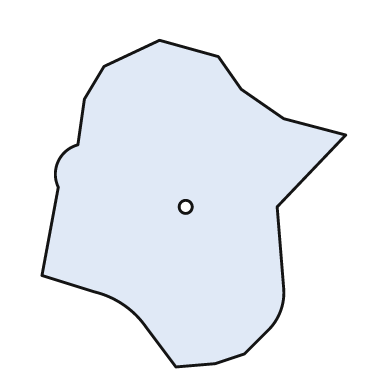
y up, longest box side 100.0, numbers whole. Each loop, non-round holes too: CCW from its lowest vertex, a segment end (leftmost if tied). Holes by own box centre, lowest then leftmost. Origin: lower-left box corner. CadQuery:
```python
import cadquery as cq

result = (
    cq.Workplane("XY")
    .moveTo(41.0, 0.0)
    .lineTo(53.0, 1.0)
    .lineTo(62.0, 4.0)
    .lineTo(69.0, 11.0)
    .threePointArc((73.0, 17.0), (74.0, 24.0))
    .lineTo(72.0, 49.0)
    .lineTo(93.0, 71.0)
    .lineTo(74.0, 76.0)
    .lineTo(61.0, 85.0)
    .lineTo(54.0, 95.0)
    .lineTo(36.0, 100.0)
    .lineTo(19.0, 92.0)
    .lineTo(13.0, 82.0)
    .lineTo(11.0, 68.0)
    .threePointArc((5.0, 63.0), (5.0, 55.0))
    .lineTo(0.0, 28.0)
    .lineTo(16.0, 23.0)
    .threePointArc((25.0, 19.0), (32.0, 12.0))
    .close()
    .moveTo(44.0, 49.0)
    .circle(2.0)
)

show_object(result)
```